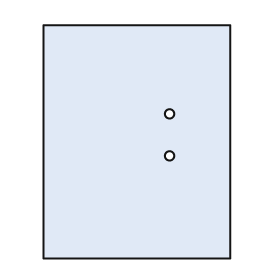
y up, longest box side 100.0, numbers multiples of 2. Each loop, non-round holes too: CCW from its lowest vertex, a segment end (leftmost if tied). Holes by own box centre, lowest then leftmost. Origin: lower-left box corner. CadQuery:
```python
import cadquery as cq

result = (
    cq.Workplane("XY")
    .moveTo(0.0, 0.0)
    .lineTo(80.0, 0.0)
    .lineTo(80.0, 100.0)
    .lineTo(0.0, 100.0)
    .close()
    .moveTo(54.0, 44.0)
    .circle(2.0)
    .moveTo(54.0, 62.0)
    .circle(2.0)
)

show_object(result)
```